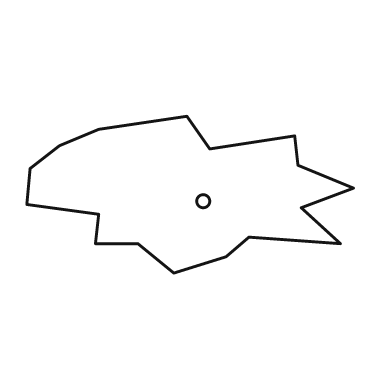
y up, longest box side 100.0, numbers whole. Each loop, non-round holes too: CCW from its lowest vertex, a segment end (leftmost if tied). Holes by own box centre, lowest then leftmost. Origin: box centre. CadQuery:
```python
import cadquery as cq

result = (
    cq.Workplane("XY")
    .moveTo(-5.0, -24.0)
    .lineTo(11.0, -19.0)
    .lineTo(18.0, -13.0)
    .lineTo(46.0, -15.0)
    .lineTo(34.0, -4.0)
    .lineTo(50.0, 2.0)
    .lineTo(33.0, 9.0)
    .lineTo(32.0, 18.0)
    .lineTo(6.0, 14.0)
    .lineTo(-1.0, 24.0)
    .lineTo(-28.0, 20.0)
    .lineTo(-40.0, 15.0)
    .lineTo(-49.0, 8.0)
    .lineTo(-50.0, -3.0)
    .lineTo(-28.0, -6.0)
    .lineTo(-29.0, -15.0)
    .lineTo(-16.0, -15.0)
    .close()
    .moveTo(4.0, -2.0)
    .circle(2.0)
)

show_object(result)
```